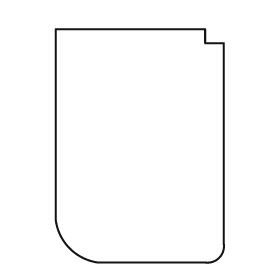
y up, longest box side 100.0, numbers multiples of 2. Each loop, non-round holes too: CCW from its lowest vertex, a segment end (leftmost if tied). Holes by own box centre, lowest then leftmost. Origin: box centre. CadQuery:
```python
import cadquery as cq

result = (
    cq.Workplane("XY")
    .moveTo(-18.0, -50.0)
    .lineTo(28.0, -50.0)
    .threePointArc((34.0, -48.0), (36.0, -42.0))
    .lineTo(36.0, 44.0)
    .lineTo(28.0, 44.0)
    .lineTo(28.0, 50.0)
    .lineTo(-36.0, 50.0)
    .lineTo(-36.0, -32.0)
    .threePointArc((-30.0, -44.0), (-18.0, -50.0))
    .close()
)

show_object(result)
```